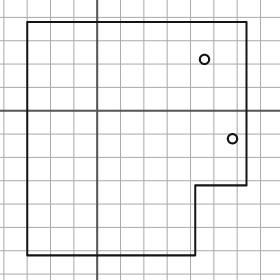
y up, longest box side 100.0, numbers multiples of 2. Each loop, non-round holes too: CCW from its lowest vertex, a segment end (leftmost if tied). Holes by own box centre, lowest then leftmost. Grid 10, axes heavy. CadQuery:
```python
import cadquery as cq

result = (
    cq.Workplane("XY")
    .moveTo(-30.0, -62.0)
    .lineTo(42.0, -62.0)
    .lineTo(42.0, -32.0)
    .lineTo(64.0, -32.0)
    .lineTo(64.0, 38.0)
    .lineTo(-30.0, 38.0)
    .close()
    .moveTo(58.0, -12.0)
    .circle(2.0)
    .moveTo(46.0, 22.0)
    .circle(2.0)
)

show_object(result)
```